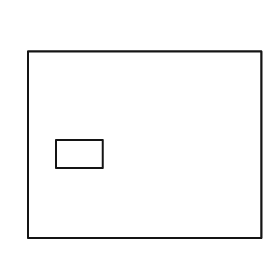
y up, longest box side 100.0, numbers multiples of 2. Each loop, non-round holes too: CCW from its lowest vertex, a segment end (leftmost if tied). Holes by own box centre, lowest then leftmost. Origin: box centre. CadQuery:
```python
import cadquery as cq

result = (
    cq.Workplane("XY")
    .moveTo(-50.0, -40.0)
    .lineTo(50.0, -40.0)
    .lineTo(50.0, 40.0)
    .lineTo(-50.0, 40.0)
    .close()
    .moveTo(-38.0, -10.0)
    .lineTo(-18.0, -10.0)
    .lineTo(-18.0, 2.0)
    .lineTo(-38.0, 2.0)
    .close()
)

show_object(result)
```